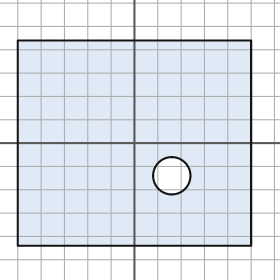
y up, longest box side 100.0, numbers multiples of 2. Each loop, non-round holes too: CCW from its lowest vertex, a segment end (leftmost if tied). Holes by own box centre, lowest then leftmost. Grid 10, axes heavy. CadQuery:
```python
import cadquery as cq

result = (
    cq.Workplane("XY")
    .moveTo(-50.0, -44.0)
    .lineTo(50.0, -44.0)
    .lineTo(50.0, 44.0)
    .lineTo(-50.0, 44.0)
    .close()
    .moveTo(16.0, -14.0)
    .circle(8.0)
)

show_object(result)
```